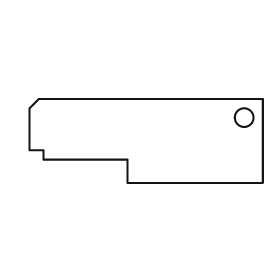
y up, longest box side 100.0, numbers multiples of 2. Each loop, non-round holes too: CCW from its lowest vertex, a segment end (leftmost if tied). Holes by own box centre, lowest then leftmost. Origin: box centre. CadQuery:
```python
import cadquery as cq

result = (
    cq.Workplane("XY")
    .moveTo(-8.0, -18.0)
    .lineTo(50.0, -18.0)
    .lineTo(50.0, 18.0)
    .lineTo(-46.0, 18.0)
    .lineTo(-50.0, 14.0)
    .lineTo(-50.0, -4.0)
    .lineTo(-44.0, -4.0)
    .lineTo(-44.0, -8.0)
    .lineTo(-8.0, -8.0)
    .close()
    .moveTo(42.0, 10.0)
    .circle(4.0)
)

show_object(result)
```